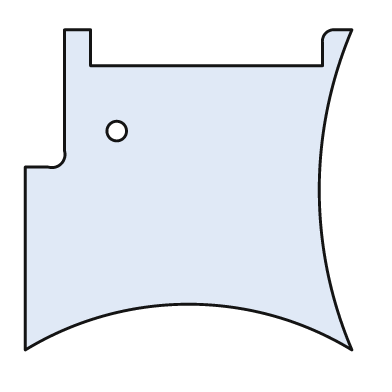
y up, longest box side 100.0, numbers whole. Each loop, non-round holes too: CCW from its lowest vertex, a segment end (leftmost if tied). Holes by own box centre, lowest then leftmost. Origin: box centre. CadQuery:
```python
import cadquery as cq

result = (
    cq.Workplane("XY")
    .moveTo(-50.0, -49.0)
    .threePointArc((0.0, -35.0), (50.0, -49.0))
    .threePointArc((40.0, 0.0), (50.0, 49.0))
    .lineTo(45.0, 49.0)
    .threePointArc((42.0, 48.0), (41.0, 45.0))
    .lineTo(41.0, 38.0)
    .lineTo(-30.0, 38.0)
    .lineTo(-30.0, 49.0)
    .lineTo(-38.0, 49.0)
    .lineTo(-38.0, 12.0)
    .threePointArc((-39.0, 8.0), (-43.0, 7.0))
    .lineTo(-50.0, 7.0)
    .close()
    .moveTo(-22.0, 18.0)
    .circle(3.0)
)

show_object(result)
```